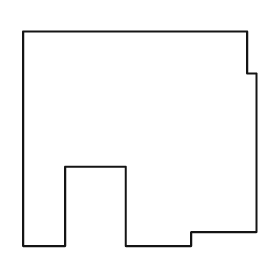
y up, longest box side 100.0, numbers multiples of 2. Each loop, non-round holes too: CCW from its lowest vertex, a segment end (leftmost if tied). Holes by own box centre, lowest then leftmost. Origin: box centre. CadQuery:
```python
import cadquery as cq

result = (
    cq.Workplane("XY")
    .moveTo(-50.0, -46.0)
    .lineTo(-32.0, -46.0)
    .lineTo(-32.0, -12.0)
    .lineTo(-6.0, -12.0)
    .lineTo(-6.0, -46.0)
    .lineTo(22.0, -46.0)
    .lineTo(22.0, -40.0)
    .lineTo(50.0, -40.0)
    .lineTo(50.0, 28.0)
    .lineTo(46.0, 28.0)
    .lineTo(46.0, 46.0)
    .lineTo(-50.0, 46.0)
    .close()
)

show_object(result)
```